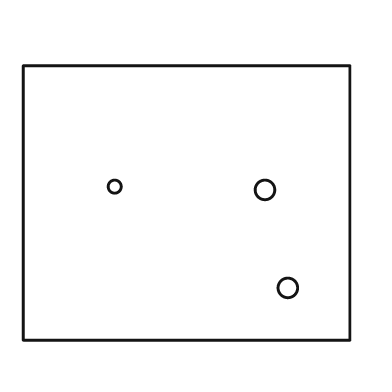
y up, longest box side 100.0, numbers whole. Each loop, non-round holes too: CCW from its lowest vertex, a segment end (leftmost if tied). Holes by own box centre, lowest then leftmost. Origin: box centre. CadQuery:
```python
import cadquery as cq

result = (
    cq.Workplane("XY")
    .moveTo(-50.0, -42.0)
    .lineTo(50.0, -42.0)
    .lineTo(50.0, 42.0)
    .lineTo(-50.0, 42.0)
    .close()
    .moveTo(31.0, -26.0)
    .circle(3.0)
    .moveTo(24.0, 4.0)
    .circle(3.0)
    .moveTo(-22.0, 5.0)
    .circle(2.0)
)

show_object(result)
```